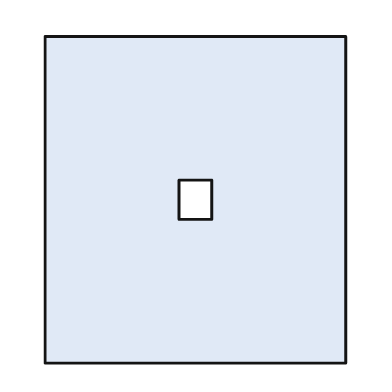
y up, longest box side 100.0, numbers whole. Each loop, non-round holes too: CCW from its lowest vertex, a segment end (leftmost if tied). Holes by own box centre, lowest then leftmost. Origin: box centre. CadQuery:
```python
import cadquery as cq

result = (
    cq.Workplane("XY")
    .moveTo(-46.0, -50.0)
    .lineTo(46.0, -50.0)
    .lineTo(46.0, 50.0)
    .lineTo(-46.0, 50.0)
    .close()
    .moveTo(-5.0, -6.0)
    .lineTo(5.0, -6.0)
    .lineTo(5.0, 6.0)
    .lineTo(-5.0, 6.0)
    .close()
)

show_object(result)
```